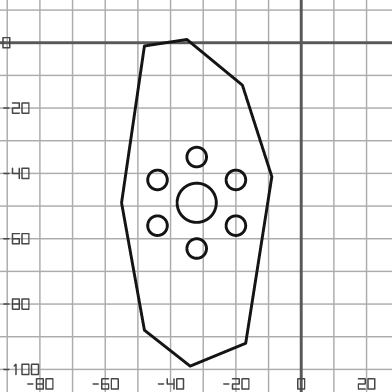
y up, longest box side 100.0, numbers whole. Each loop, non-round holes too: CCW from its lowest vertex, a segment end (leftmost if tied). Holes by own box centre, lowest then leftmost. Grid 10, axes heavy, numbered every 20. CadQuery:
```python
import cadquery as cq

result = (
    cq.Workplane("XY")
    .moveTo(-34.0, -99.0)
    .lineTo(-17.0, -92.0)
    .lineTo(-9.0, -41.0)
    .lineTo(-18.0, -13.0)
    .lineTo(-35.0, 1.0)
    .lineTo(-48.0, -1.0)
    .lineTo(-55.0, -49.0)
    .lineTo(-48.0, -88.0)
    .close()
    .moveTo(-32.0, -63.0)
    .circle(3.0)
    .moveTo(-44.0, -56.0)
    .circle(3.0)
    .moveTo(-20.0, -56.0)
    .circle(3.0)
    .moveTo(-32.0, -49.0)
    .circle(6.0)
    .moveTo(-44.0, -42.0)
    .circle(3.0)
    .moveTo(-20.0, -42.0)
    .circle(3.0)
    .moveTo(-32.0, -35.0)
    .circle(3.0)
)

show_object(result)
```